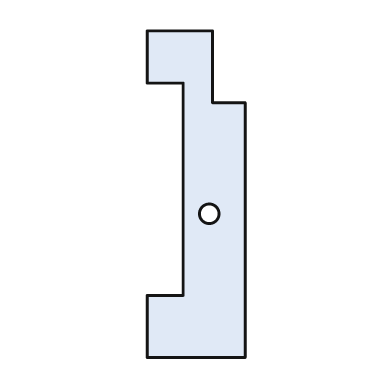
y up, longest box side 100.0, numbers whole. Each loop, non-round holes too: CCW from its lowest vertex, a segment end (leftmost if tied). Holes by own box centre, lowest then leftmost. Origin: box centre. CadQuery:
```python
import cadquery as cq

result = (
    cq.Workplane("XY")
    .moveTo(-15.0, -50.0)
    .lineTo(15.0, -50.0)
    .lineTo(15.0, 28.0)
    .lineTo(5.0, 28.0)
    .lineTo(5.0, 50.0)
    .lineTo(-15.0, 50.0)
    .lineTo(-15.0, 34.0)
    .lineTo(-4.0, 34.0)
    .lineTo(-4.0, -31.0)
    .lineTo(-15.0, -31.0)
    .close()
    .moveTo(4.0, -6.0)
    .circle(3.0)
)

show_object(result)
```